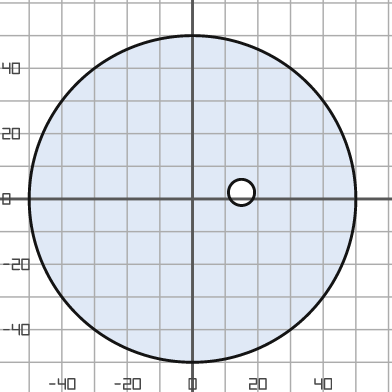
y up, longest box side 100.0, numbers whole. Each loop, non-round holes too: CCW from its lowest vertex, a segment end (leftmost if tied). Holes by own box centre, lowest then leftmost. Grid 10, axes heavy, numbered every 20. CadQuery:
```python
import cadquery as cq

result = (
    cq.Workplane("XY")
    .moveTo(0.0, 0.0)
    .circle(50.0)
    .moveTo(15.0, 2.0)
    .circle(4.0)
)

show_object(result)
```